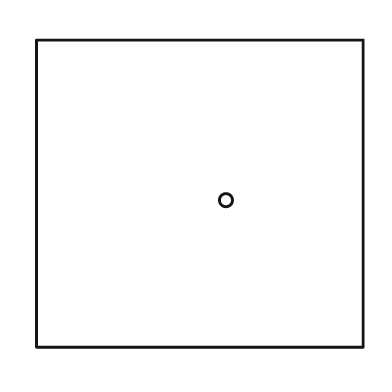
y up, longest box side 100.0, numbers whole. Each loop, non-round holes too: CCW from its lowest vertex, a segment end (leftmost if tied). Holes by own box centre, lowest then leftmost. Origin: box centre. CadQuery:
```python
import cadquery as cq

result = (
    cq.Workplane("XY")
    .moveTo(-50.0, -47.0)
    .lineTo(50.0, -47.0)
    .lineTo(50.0, 47.0)
    .lineTo(-50.0, 47.0)
    .close()
    .moveTo(8.0, -2.0)
    .circle(2.0)
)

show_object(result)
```